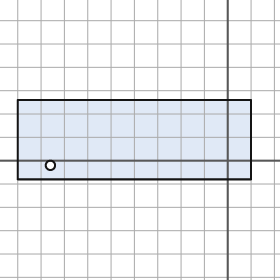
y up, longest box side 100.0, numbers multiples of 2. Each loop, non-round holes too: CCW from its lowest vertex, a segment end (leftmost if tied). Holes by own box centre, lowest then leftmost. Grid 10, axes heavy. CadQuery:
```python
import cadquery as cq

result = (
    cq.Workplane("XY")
    .moveTo(-90.0, -8.0)
    .lineTo(10.0, -8.0)
    .lineTo(10.0, 26.0)
    .lineTo(-90.0, 26.0)
    .close()
    .moveTo(-76.0, -2.0)
    .circle(2.0)
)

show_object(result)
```